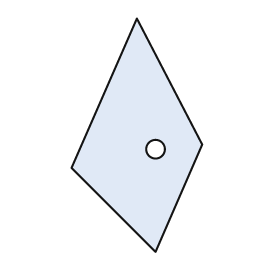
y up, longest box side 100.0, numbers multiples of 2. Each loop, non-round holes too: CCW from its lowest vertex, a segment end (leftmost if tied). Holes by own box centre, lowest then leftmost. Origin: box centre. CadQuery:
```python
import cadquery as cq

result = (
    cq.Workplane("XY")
    .moveTo(8.0, -50.0)
    .lineTo(28.0, -4.0)
    .lineTo(0.0, 50.0)
    .lineTo(-28.0, -14.0)
    .close()
    .moveTo(8.0, -6.0)
    .circle(4.0)
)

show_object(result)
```